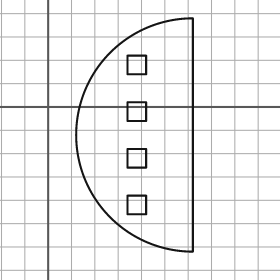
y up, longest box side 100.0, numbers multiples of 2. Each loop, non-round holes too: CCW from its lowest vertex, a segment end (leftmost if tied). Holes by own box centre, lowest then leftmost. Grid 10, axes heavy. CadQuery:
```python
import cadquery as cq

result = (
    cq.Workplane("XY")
    .moveTo(62.0, -62.0)
    .lineTo(62.0, 38.0)
    .threePointArc((12.0, -12.0), (62.0, -62.0))
    .close()
    .moveTo(34.0, -46.0)
    .lineTo(42.0, -46.0)
    .lineTo(42.0, -38.0)
    .lineTo(34.0, -38.0)
    .close()
    .moveTo(34.0, -26.0)
    .lineTo(42.0, -26.0)
    .lineTo(42.0, -18.0)
    .lineTo(34.0, -18.0)
    .close()
    .moveTo(34.0, -6.0)
    .lineTo(42.0, -6.0)
    .lineTo(42.0, 2.0)
    .lineTo(34.0, 2.0)
    .close()
    .moveTo(34.0, 14.0)
    .lineTo(42.0, 14.0)
    .lineTo(42.0, 22.0)
    .lineTo(34.0, 22.0)
    .close()
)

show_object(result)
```